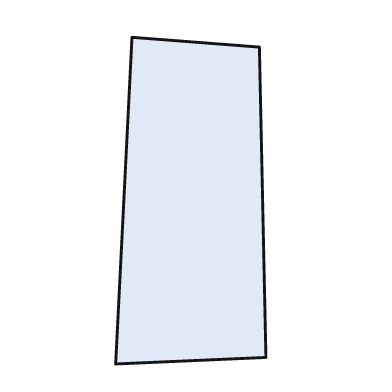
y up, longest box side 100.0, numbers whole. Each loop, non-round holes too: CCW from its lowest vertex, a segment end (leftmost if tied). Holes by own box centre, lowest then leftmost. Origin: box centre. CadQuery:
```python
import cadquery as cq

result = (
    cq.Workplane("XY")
    .moveTo(-23.0, -50.0)
    .lineTo(23.0, -48.0)
    .lineTo(21.0, 47.0)
    .lineTo(-18.0, 50.0)
    .close()
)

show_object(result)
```